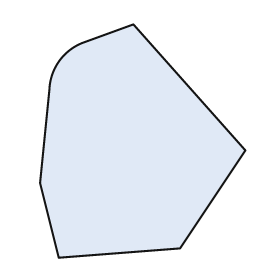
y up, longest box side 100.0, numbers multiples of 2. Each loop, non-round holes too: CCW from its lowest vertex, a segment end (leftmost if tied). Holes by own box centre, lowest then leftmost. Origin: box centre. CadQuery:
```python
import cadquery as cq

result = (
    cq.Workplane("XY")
    .moveTo(-36.0, -50.0)
    .lineTo(16.0, -46.0)
    .lineTo(44.0, -4.0)
    .lineTo(-4.0, 50.0)
    .lineTo(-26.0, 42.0)
    .threePointArc((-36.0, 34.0), (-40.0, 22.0))
    .lineTo(-44.0, -18.0)
    .close()
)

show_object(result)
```